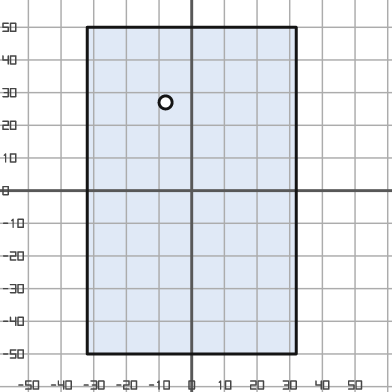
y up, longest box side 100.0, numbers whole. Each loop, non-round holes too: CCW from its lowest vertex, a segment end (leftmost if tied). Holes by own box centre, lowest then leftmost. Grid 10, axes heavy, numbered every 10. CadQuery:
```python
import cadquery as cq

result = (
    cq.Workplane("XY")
    .moveTo(-32.0, -50.0)
    .lineTo(32.0, -50.0)
    .lineTo(32.0, 50.0)
    .lineTo(-32.0, 50.0)
    .close()
    .moveTo(-8.0, 27.0)
    .circle(2.0)
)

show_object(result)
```